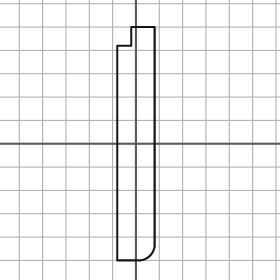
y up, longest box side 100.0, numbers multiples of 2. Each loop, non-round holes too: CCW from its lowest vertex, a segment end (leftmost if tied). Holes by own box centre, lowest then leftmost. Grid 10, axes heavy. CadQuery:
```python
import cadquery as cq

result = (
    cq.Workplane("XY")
    .moveTo(-8.0, -50.0)
    .lineTo(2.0, -50.0)
    .threePointArc((6.0, -48.0), (8.0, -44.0))
    .lineTo(8.0, 50.0)
    .lineTo(-2.0, 50.0)
    .lineTo(-2.0, 42.0)
    .lineTo(-8.0, 42.0)
    .close()
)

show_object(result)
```